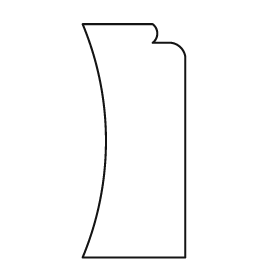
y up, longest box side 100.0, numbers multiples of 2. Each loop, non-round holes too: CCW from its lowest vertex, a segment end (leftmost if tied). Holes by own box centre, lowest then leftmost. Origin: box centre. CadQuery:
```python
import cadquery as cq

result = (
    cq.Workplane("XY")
    .moveTo(-22.0, -50.0)
    .lineTo(22.0, -50.0)
    .lineTo(22.0, 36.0)
    .threePointArc((20.0, 40.0), (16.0, 42.0))
    .lineTo(8.0, 42.0)
    .threePointArc((10.0, 46.0), (8.0, 50.0))
    .lineTo(-22.0, 50.0)
    .threePointArc((-12.0, 0.0), (-22.0, -50.0))
    .close()
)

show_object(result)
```